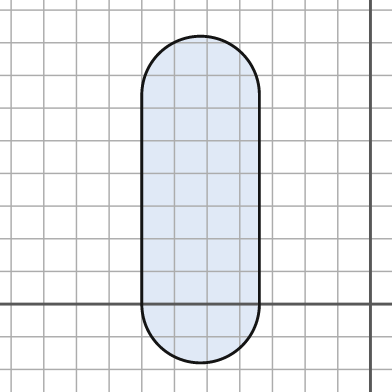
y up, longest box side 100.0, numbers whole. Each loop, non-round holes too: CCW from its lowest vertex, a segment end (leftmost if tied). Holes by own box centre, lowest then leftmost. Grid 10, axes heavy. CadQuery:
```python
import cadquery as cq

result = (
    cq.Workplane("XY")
    .moveTo(-70.0, 0.0)
    .threePointArc((-52.0, -18.0), (-34.0, 0.0))
    .lineTo(-34.0, 64.0)
    .threePointArc((-52.0, 82.0), (-70.0, 64.0))
    .close()
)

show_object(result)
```